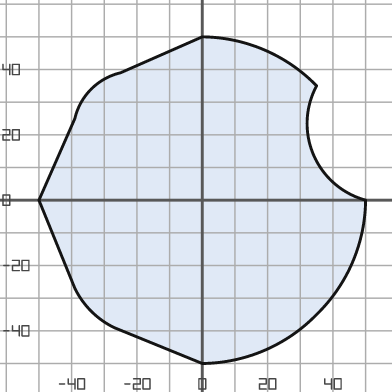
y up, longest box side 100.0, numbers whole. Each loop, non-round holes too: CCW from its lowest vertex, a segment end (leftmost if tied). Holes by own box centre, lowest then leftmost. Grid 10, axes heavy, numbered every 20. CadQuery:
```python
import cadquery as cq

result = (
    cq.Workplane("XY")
    .moveTo(0.0, -50.0)
    .threePointArc((19.0, -46.0), (35.0, -35.0))
    .threePointArc((46.0, -19.0), (50.0, 0.0))
    .threePointArc((34.0, 14.0), (35.0, 35.0))
    .threePointArc((19.0, 46.0), (0.0, 50.0))
    .lineTo(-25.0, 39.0)
    .threePointArc((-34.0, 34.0), (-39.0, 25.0))
    .lineTo(-50.0, 0.0)
    .lineTo(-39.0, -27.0)
    .threePointArc((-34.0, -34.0), (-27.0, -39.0))
    .close()
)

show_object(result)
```